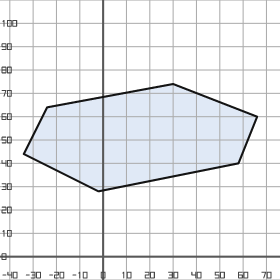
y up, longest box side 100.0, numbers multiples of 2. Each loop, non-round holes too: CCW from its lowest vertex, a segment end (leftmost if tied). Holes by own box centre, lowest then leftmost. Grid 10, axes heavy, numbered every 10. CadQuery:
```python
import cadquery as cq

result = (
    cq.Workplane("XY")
    .moveTo(-2.0, 28.0)
    .lineTo(58.0, 40.0)
    .lineTo(66.0, 60.0)
    .lineTo(30.0, 74.0)
    .lineTo(-24.0, 64.0)
    .lineTo(-34.0, 44.0)
    .close()
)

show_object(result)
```